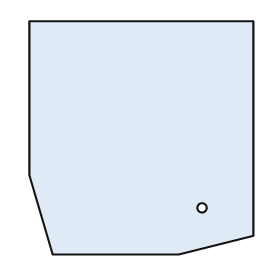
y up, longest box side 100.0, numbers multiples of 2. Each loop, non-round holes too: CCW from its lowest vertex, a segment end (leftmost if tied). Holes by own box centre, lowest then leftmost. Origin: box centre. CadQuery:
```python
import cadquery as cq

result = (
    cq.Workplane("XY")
    .moveTo(-38.0, -50.0)
    .lineTo(16.0, -50.0)
    .lineTo(48.0, -42.0)
    .lineTo(48.0, 50.0)
    .lineTo(-48.0, 50.0)
    .lineTo(-48.0, -16.0)
    .close()
    .moveTo(26.0, -30.0)
    .circle(2.0)
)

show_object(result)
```